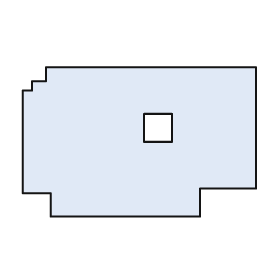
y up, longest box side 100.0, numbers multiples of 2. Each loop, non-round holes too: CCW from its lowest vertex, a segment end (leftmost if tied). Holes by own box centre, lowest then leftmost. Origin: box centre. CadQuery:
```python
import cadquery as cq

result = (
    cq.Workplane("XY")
    .moveTo(-38.0, -32.0)
    .lineTo(26.0, -32.0)
    .lineTo(26.0, -20.0)
    .lineTo(50.0, -20.0)
    .lineTo(50.0, 32.0)
    .lineTo(-40.0, 32.0)
    .lineTo(-40.0, 26.0)
    .lineTo(-46.0, 26.0)
    .lineTo(-46.0, 22.0)
    .lineTo(-50.0, 22.0)
    .lineTo(-50.0, -22.0)
    .lineTo(-38.0, -22.0)
    .close()
    .moveTo(2.0, 0.0)
    .lineTo(14.0, 0.0)
    .lineTo(14.0, 12.0)
    .lineTo(2.0, 12.0)
    .close()
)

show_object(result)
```